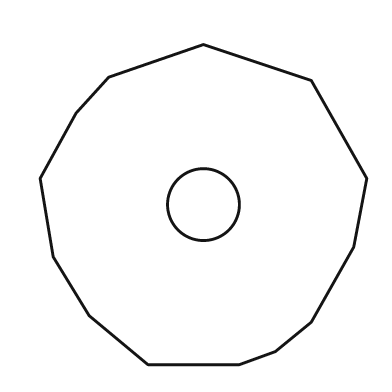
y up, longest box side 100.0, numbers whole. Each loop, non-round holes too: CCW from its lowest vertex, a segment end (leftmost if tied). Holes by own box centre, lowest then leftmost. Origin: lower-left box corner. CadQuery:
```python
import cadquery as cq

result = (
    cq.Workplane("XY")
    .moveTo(33.0, 0.0)
    .lineTo(61.0, 0.0)
    .lineTo(72.0, 4.0)
    .lineTo(83.0, 13.0)
    .lineTo(96.0, 36.0)
    .lineTo(100.0, 57.0)
    .lineTo(83.0, 87.0)
    .lineTo(50.0, 98.0)
    .lineTo(21.0, 88.0)
    .lineTo(11.0, 77.0)
    .lineTo(0.0, 57.0)
    .lineTo(4.0, 33.0)
    .lineTo(15.0, 15.0)
    .close()
    .moveTo(50.0, 49.0)
    .circle(11.0)
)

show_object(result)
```